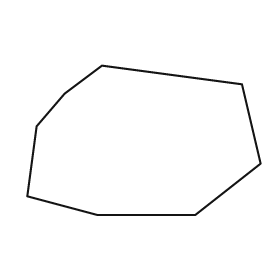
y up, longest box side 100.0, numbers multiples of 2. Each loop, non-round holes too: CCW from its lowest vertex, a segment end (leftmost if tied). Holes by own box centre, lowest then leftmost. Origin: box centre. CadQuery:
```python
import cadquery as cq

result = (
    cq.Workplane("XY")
    .moveTo(-20.0, -32.0)
    .lineTo(22.0, -32.0)
    .lineTo(50.0, -10.0)
    .lineTo(42.0, 24.0)
    .lineTo(-18.0, 32.0)
    .lineTo(-34.0, 20.0)
    .lineTo(-46.0, 6.0)
    .lineTo(-50.0, -24.0)
    .close()
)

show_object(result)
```